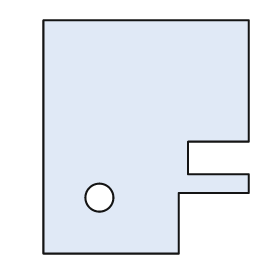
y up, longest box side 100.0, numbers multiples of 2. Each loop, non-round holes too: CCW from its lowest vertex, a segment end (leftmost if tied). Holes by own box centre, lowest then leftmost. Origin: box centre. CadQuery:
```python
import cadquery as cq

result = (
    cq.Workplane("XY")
    .moveTo(-44.0, -50.0)
    .lineTo(14.0, -50.0)
    .lineTo(14.0, -24.0)
    .lineTo(44.0, -24.0)
    .lineTo(44.0, -16.0)
    .lineTo(18.0, -16.0)
    .lineTo(18.0, -2.0)
    .lineTo(44.0, -2.0)
    .lineTo(44.0, 50.0)
    .lineTo(-44.0, 50.0)
    .close()
    .moveTo(-20.0, -26.0)
    .circle(6.0)
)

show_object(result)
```